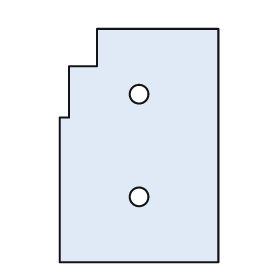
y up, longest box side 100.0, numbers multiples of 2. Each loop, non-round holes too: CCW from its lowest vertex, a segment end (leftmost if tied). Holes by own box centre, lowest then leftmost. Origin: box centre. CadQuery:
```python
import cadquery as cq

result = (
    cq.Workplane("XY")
    .moveTo(-34.0, -50.0)
    .lineTo(34.0, -50.0)
    .lineTo(34.0, 50.0)
    .lineTo(-18.0, 50.0)
    .lineTo(-18.0, 34.0)
    .lineTo(-30.0, 34.0)
    .lineTo(-30.0, 12.0)
    .lineTo(-34.0, 12.0)
    .close()
    .moveTo(0.0, -22.0)
    .circle(4.0)
    .moveTo(0.0, 22.0)
    .circle(4.0)
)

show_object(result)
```